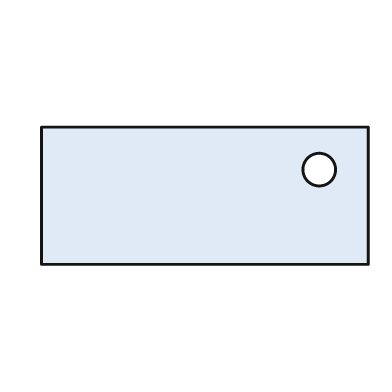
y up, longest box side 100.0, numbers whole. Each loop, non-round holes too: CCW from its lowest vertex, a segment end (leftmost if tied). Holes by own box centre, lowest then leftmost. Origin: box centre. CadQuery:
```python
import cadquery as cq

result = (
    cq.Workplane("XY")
    .moveTo(-50.0, -21.0)
    .lineTo(50.0, -21.0)
    .lineTo(50.0, 21.0)
    .lineTo(-50.0, 21.0)
    .close()
    .moveTo(35.0, 8.0)
    .circle(5.0)
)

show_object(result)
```